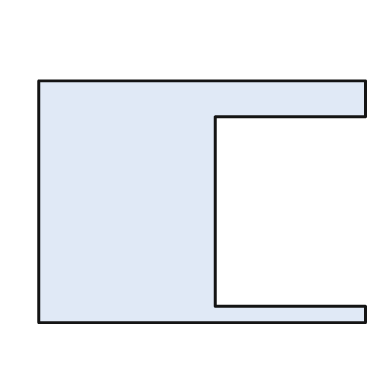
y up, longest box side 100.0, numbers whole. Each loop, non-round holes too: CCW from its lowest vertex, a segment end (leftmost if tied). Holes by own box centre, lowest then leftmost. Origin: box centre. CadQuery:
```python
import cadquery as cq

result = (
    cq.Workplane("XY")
    .moveTo(-50.0, -37.0)
    .lineTo(50.0, -37.0)
    .lineTo(50.0, -32.0)
    .lineTo(4.0, -32.0)
    .lineTo(4.0, 26.0)
    .lineTo(50.0, 26.0)
    .lineTo(50.0, 37.0)
    .lineTo(-50.0, 37.0)
    .close()
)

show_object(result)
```